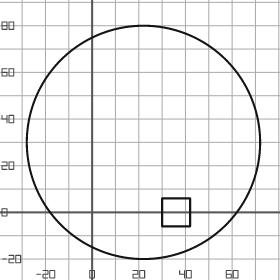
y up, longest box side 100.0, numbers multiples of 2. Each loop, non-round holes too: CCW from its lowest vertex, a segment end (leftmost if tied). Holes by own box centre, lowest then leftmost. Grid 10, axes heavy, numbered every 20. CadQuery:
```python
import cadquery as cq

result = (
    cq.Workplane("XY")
    .moveTo(22.0, 30.0)
    .circle(50.0)
    .moveTo(30.0, -6.0)
    .lineTo(42.0, -6.0)
    .lineTo(42.0, 6.0)
    .lineTo(30.0, 6.0)
    .close()
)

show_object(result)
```